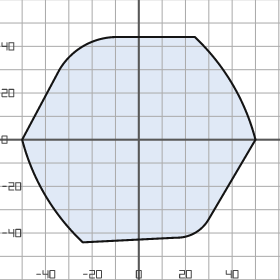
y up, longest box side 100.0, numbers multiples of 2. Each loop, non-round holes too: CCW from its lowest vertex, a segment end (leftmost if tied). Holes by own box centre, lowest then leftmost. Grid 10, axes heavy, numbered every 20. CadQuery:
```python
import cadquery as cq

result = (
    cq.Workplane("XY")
    .moveTo(-24.0, -44.0)
    .lineTo(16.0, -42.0)
    .threePointArc((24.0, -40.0), (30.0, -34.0))
    .lineTo(50.0, 0.0)
    .threePointArc((40.0, 24.0), (24.0, 44.0))
    .lineTo(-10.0, 44.0)
    .threePointArc((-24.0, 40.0), (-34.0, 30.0))
    .lineTo(-50.0, 0.0)
    .threePointArc((-40.0, -24.0), (-24.0, -44.0))
    .close()
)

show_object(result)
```